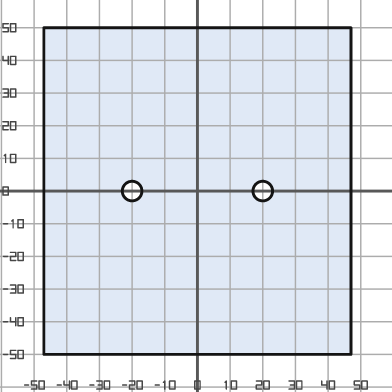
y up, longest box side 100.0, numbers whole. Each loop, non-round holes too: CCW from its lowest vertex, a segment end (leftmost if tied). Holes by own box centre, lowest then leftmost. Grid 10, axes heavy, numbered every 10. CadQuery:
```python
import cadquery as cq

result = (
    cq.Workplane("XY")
    .moveTo(-47.0, -50.0)
    .lineTo(47.0, -50.0)
    .lineTo(47.0, 50.0)
    .lineTo(-47.0, 50.0)
    .close()
    .moveTo(-20.0, 0.0)
    .circle(3.0)
    .moveTo(20.0, 0.0)
    .circle(3.0)
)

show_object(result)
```